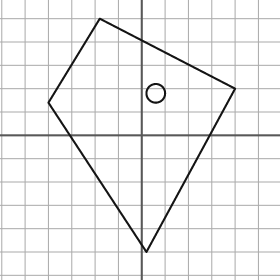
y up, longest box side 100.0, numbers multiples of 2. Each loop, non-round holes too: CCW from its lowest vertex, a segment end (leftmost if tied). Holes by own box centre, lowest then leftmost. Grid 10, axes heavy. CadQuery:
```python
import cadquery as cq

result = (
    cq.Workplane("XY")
    .moveTo(2.0, -50.0)
    .lineTo(40.0, 20.0)
    .lineTo(-18.0, 50.0)
    .lineTo(-40.0, 14.0)
    .close()
    .moveTo(6.0, 18.0)
    .circle(4.0)
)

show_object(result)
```